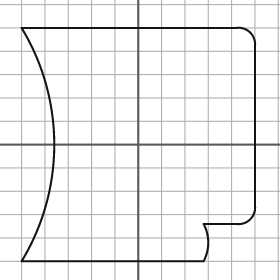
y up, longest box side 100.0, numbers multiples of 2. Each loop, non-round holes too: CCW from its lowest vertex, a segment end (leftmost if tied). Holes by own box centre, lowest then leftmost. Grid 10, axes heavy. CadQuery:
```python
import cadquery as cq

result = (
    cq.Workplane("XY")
    .moveTo(-50.0, -50.0)
    .lineTo(28.0, -50.0)
    .threePointArc((30.0, -42.0), (28.0, -34.0))
    .lineTo(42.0, -34.0)
    .threePointArc((48.0, -32.0), (50.0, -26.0))
    .lineTo(50.0, 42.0)
    .threePointArc((48.0, 48.0), (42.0, 50.0))
    .lineTo(-50.0, 50.0)
    .threePointArc((-36.0, 0.0), (-50.0, -50.0))
    .close()
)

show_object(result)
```